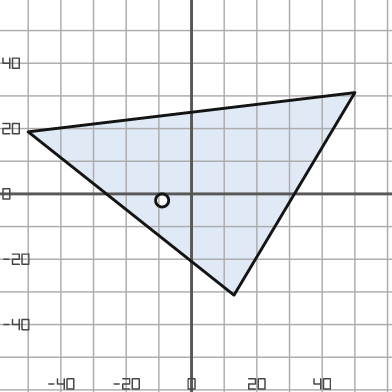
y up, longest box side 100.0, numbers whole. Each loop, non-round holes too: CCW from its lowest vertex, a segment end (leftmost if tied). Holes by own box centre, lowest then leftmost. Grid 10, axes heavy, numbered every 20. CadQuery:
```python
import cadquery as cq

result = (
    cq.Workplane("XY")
    .moveTo(13.0, -31.0)
    .lineTo(50.0, 31.0)
    .lineTo(-50.0, 19.0)
    .close()
    .moveTo(-9.0, -2.0)
    .circle(2.0)
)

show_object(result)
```